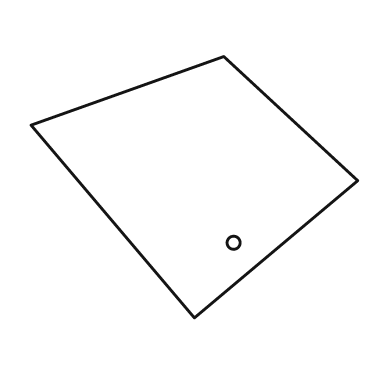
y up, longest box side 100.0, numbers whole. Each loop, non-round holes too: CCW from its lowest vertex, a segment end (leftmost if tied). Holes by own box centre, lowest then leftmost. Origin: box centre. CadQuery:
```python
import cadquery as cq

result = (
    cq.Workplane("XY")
    .moveTo(0.0, -40.0)
    .lineTo(50.0, 2.0)
    .lineTo(9.0, 40.0)
    .lineTo(-50.0, 19.0)
    .close()
    .moveTo(12.0, -17.0)
    .circle(2.0)
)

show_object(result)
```